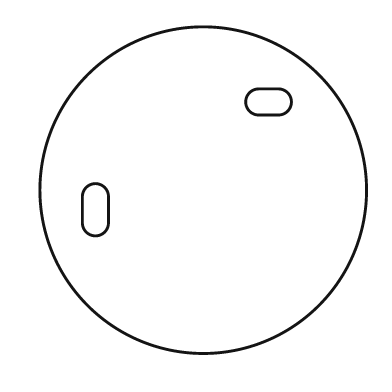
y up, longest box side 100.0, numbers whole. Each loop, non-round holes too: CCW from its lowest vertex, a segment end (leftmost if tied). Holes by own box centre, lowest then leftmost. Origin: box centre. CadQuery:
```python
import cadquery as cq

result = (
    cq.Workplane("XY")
    .moveTo(0.0, 0.0)
    .circle(50.0)
    .moveTo(-37.0, -10.0)
    .threePointArc((-33.0, -14.0), (-29.0, -10.0))
    .lineTo(-29.0, -2.0)
    .threePointArc((-33.0, 2.0), (-37.0, -2.0))
    .close()
    .moveTo(17.0, 23.0)
    .lineTo(23.0, 23.0)
    .threePointArc((27.0, 27.0), (23.0, 31.0))
    .lineTo(17.0, 31.0)
    .threePointArc((13.0, 27.0), (17.0, 23.0))
    .close()
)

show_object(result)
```